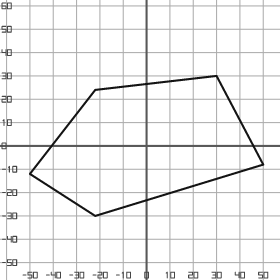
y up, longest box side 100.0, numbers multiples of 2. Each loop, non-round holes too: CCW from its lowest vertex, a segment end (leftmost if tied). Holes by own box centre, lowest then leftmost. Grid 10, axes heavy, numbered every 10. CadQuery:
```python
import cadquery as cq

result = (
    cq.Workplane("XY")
    .moveTo(-22.0, -30.0)
    .lineTo(50.0, -8.0)
    .lineTo(30.0, 30.0)
    .lineTo(-22.0, 24.0)
    .lineTo(-50.0, -12.0)
    .close()
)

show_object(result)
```